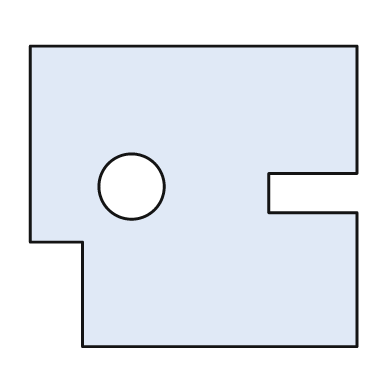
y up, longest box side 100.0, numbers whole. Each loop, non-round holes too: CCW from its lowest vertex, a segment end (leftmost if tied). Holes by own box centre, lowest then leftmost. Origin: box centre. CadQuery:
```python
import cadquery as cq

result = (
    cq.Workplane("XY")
    .moveTo(-34.0, -46.0)
    .lineTo(50.0, -46.0)
    .lineTo(50.0, -5.0)
    .lineTo(23.0, -5.0)
    .lineTo(23.0, 7.0)
    .lineTo(50.0, 7.0)
    .lineTo(50.0, 46.0)
    .lineTo(-50.0, 46.0)
    .lineTo(-50.0, -14.0)
    .lineTo(-34.0, -14.0)
    .close()
    .moveTo(-19.0, 3.0)
    .circle(10.0)
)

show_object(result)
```